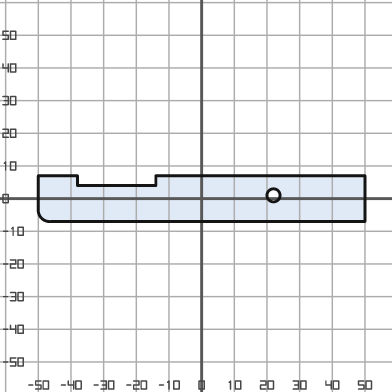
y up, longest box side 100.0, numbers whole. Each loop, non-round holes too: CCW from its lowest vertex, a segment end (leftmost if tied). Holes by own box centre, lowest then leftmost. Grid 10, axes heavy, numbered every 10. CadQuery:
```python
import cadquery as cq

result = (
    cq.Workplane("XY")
    .moveTo(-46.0, -7.0)
    .lineTo(50.0, -7.0)
    .lineTo(50.0, 7.0)
    .lineTo(-14.0, 7.0)
    .lineTo(-14.0, 4.0)
    .lineTo(-38.0, 4.0)
    .lineTo(-38.0, 7.0)
    .lineTo(-50.0, 7.0)
    .lineTo(-50.0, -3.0)
    .threePointArc((-49.0, -6.0), (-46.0, -7.0))
    .close()
    .moveTo(22.0, 1.0)
    .circle(2.0)
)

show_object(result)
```